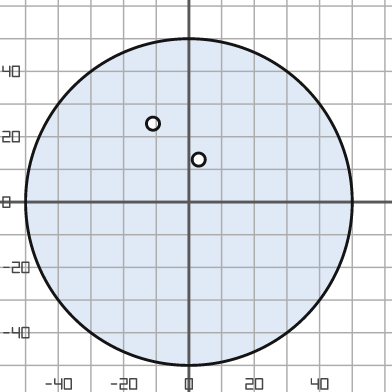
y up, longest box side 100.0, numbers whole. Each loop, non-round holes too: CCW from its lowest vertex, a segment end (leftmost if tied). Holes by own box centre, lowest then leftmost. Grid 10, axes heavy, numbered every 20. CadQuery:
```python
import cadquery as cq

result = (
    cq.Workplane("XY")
    .moveTo(0.0, 0.0)
    .circle(50.0)
    .moveTo(3.0, 13.0)
    .circle(2.0)
    .moveTo(-11.0, 24.0)
    .circle(2.0)
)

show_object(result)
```